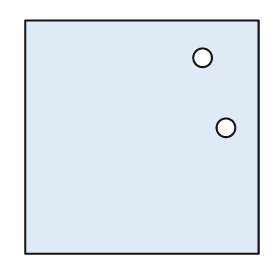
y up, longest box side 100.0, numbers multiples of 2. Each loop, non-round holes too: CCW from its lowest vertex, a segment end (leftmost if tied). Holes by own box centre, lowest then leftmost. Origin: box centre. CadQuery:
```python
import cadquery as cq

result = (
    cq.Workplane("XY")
    .moveTo(-50.0, -50.0)
    .lineTo(50.0, -50.0)
    .lineTo(50.0, 50.0)
    .lineTo(-50.0, 50.0)
    .close()
    .moveTo(36.0, 4.0)
    .circle(4.0)
    .moveTo(26.0, 34.0)
    .circle(4.0)
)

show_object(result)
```